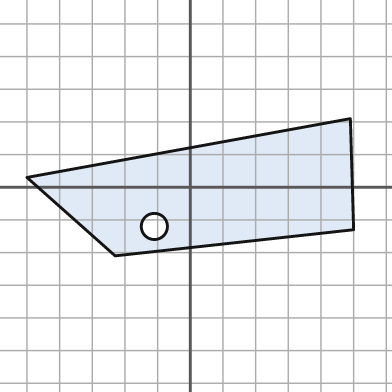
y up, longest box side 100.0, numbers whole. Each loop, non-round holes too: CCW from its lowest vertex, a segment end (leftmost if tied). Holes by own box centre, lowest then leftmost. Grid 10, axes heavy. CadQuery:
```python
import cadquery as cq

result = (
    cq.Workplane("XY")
    .moveTo(-23.0, -21.0)
    .lineTo(50.0, -13.0)
    .lineTo(49.0, 21.0)
    .lineTo(-50.0, 3.0)
    .close()
    .moveTo(-11.0, -12.0)
    .circle(4.0)
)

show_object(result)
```